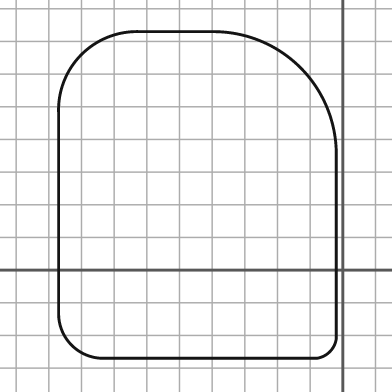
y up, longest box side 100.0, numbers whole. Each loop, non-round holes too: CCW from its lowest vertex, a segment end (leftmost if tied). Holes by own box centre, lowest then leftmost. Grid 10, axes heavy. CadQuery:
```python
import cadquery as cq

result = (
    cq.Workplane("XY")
    .moveTo(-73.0, -27.0)
    .lineTo(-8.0, -27.0)
    .threePointArc((-4.0, -25.0), (-2.0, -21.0))
    .lineTo(-2.0, 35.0)
    .threePointArc((-13.0, 62.0), (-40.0, 73.0))
    .lineTo(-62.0, 73.0)
    .threePointArc((-80.0, 66.0), (-87.0, 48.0))
    .lineTo(-87.0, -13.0)
    .threePointArc((-83.0, -23.0), (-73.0, -27.0))
    .close()
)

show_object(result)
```